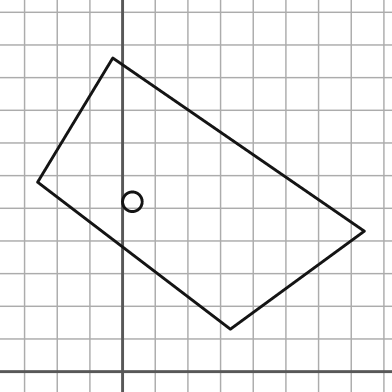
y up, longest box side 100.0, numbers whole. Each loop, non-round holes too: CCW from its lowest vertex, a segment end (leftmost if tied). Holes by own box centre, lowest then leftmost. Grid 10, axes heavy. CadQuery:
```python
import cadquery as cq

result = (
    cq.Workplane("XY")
    .moveTo(33.0, 13.0)
    .lineTo(74.0, 43.0)
    .lineTo(-3.0, 96.0)
    .lineTo(-26.0, 58.0)
    .close()
    .moveTo(3.0, 52.0)
    .circle(3.0)
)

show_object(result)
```